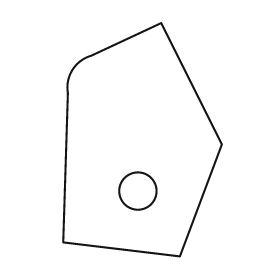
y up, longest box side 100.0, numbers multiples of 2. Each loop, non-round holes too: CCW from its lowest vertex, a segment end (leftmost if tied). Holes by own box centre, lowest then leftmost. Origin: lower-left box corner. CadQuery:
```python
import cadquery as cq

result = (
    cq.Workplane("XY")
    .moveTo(50.0, 0.0)
    .lineTo(68.0, 48.0)
    .lineTo(42.0, 100.0)
    .lineTo(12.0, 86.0)
    .threePointArc((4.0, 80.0), (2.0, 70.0))
    .lineTo(0.0, 6.0)
    .close()
    .moveTo(32.0, 28.0)
    .circle(8.0)
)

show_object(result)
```